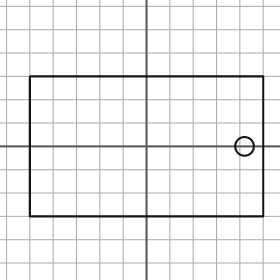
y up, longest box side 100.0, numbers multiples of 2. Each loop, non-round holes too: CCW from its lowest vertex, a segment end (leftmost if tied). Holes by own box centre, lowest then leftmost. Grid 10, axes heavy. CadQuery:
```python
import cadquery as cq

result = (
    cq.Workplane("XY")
    .moveTo(-50.0, -30.0)
    .lineTo(50.0, -30.0)
    .lineTo(50.0, 30.0)
    .lineTo(-50.0, 30.0)
    .close()
    .moveTo(42.0, 0.0)
    .circle(4.0)
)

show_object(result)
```